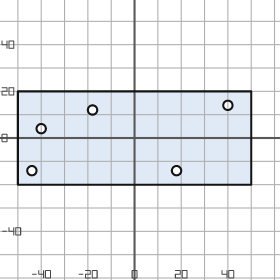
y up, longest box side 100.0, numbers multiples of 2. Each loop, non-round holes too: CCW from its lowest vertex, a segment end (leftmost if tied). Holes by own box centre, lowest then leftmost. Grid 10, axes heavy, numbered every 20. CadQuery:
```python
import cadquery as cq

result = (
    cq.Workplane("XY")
    .moveTo(-50.0, -20.0)
    .lineTo(50.0, -20.0)
    .lineTo(50.0, 20.0)
    .lineTo(-50.0, 20.0)
    .close()
    .moveTo(-44.0, -14.0)
    .circle(2.0)
    .moveTo(18.0, -14.0)
    .circle(2.0)
    .moveTo(-40.0, 4.0)
    .circle(2.0)
    .moveTo(-18.0, 12.0)
    .circle(2.0)
    .moveTo(40.0, 14.0)
    .circle(2.0)
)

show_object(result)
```